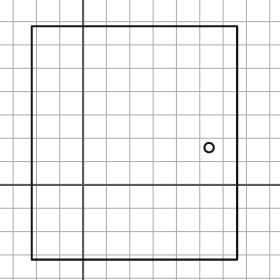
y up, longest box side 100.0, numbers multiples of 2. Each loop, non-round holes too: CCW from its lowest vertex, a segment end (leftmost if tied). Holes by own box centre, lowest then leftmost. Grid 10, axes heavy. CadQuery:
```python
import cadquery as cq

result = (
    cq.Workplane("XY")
    .moveTo(-22.0, -32.0)
    .lineTo(66.0, -32.0)
    .lineTo(66.0, 68.0)
    .lineTo(-22.0, 68.0)
    .close()
    .moveTo(54.0, 16.0)
    .circle(2.0)
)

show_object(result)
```